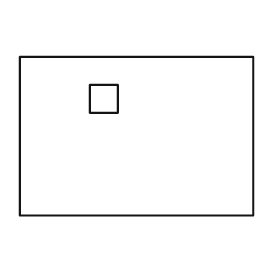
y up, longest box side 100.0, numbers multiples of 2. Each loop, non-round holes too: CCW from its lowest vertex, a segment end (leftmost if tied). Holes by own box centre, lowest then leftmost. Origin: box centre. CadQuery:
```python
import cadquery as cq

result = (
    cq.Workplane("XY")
    .moveTo(-50.0, -34.0)
    .lineTo(50.0, -34.0)
    .lineTo(50.0, 34.0)
    .lineTo(-50.0, 34.0)
    .close()
    .moveTo(-20.0, 10.0)
    .lineTo(-8.0, 10.0)
    .lineTo(-8.0, 22.0)
    .lineTo(-20.0, 22.0)
    .close()
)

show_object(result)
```